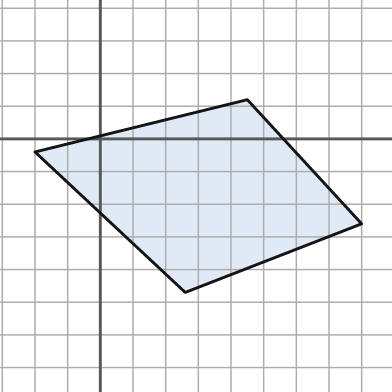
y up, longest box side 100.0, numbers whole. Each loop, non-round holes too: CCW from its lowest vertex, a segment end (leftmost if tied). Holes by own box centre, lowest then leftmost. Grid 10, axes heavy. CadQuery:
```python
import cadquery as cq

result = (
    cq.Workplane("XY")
    .moveTo(26.0, -47.0)
    .lineTo(80.0, -26.0)
    .lineTo(45.0, 12.0)
    .lineTo(-20.0, -4.0)
    .close()
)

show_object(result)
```